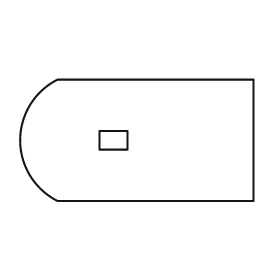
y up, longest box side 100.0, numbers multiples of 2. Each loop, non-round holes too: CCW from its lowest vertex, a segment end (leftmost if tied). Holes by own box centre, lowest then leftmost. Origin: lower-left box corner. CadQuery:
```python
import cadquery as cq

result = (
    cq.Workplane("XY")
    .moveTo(16.0, 0.0)
    .lineTo(100.0, 0.0)
    .lineTo(100.0, 52.0)
    .lineTo(16.0, 52.0)
    .threePointArc((0.0, 26.0), (16.0, 0.0))
    .close()
    .moveTo(34.0, 22.0)
    .lineTo(46.0, 22.0)
    .lineTo(46.0, 30.0)
    .lineTo(34.0, 30.0)
    .close()
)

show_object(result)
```